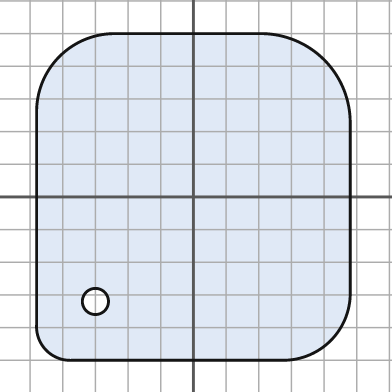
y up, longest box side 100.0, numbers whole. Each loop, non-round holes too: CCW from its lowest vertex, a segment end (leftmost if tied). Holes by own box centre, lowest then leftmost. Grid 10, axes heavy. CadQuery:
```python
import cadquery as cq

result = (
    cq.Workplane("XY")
    .moveTo(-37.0, -50.0)
    .lineTo(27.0, -50.0)
    .threePointArc((42.0, -44.0), (48.0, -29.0))
    .lineTo(48.0, 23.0)
    .threePointArc((40.0, 42.0), (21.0, 50.0))
    .lineTo(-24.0, 50.0)
    .threePointArc((-41.0, 43.0), (-48.0, 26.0))
    .lineTo(-48.0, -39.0)
    .threePointArc((-45.0, -47.0), (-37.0, -50.0))
    .close()
    .moveTo(-30.0, -32.0)
    .circle(4.0)
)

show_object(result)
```